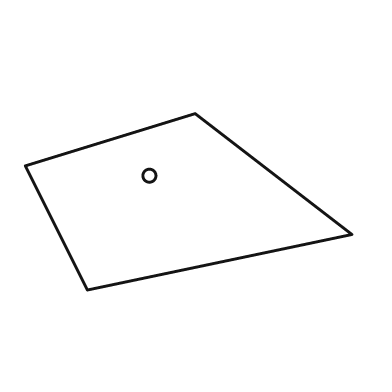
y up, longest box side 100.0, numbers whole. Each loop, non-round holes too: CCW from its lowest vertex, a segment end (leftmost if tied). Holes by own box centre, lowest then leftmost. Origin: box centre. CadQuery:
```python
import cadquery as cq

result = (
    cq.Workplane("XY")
    .moveTo(-31.0, -27.0)
    .lineTo(50.0, -10.0)
    .lineTo(2.0, 27.0)
    .lineTo(-50.0, 11.0)
    .close()
    .moveTo(-12.0, 8.0)
    .circle(2.0)
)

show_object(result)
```